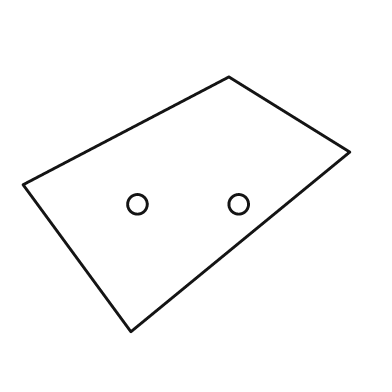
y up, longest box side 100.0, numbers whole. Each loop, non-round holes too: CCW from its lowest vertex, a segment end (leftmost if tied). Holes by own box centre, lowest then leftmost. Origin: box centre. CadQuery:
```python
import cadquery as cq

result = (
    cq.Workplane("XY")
    .moveTo(-17.0, -39.0)
    .lineTo(50.0, 16.0)
    .lineTo(13.0, 39.0)
    .lineTo(-50.0, 6.0)
    .close()
    .moveTo(-15.0, 0.0)
    .circle(3.0)
    .moveTo(16.0, 0.0)
    .circle(3.0)
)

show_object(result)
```